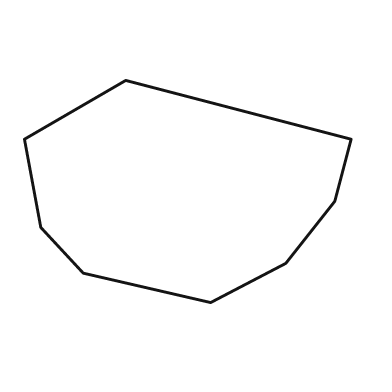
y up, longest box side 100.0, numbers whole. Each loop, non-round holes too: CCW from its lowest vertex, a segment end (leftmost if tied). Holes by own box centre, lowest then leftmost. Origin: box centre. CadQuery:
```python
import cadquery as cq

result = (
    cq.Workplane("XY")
    .moveTo(7.0, -34.0)
    .lineTo(30.0, -22.0)
    .lineTo(45.0, -3.0)
    .lineTo(50.0, 16.0)
    .lineTo(-19.0, 34.0)
    .lineTo(-50.0, 16.0)
    .lineTo(-45.0, -11.0)
    .lineTo(-32.0, -25.0)
    .close()
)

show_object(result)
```